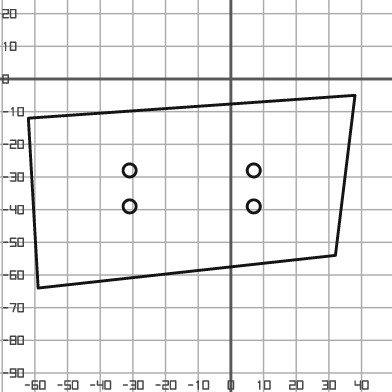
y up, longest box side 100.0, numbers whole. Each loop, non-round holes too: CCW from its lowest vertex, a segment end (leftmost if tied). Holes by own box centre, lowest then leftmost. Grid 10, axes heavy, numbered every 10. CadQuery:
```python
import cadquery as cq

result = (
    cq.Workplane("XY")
    .moveTo(-59.0, -64.0)
    .lineTo(32.0, -54.0)
    .lineTo(38.0, -5.0)
    .lineTo(-62.0, -12.0)
    .close()
    .moveTo(-31.0, -39.0)
    .circle(2.0)
    .moveTo(7.0, -39.0)
    .circle(2.0)
    .moveTo(-31.0, -28.0)
    .circle(2.0)
    .moveTo(7.0, -28.0)
    .circle(2.0)
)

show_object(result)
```